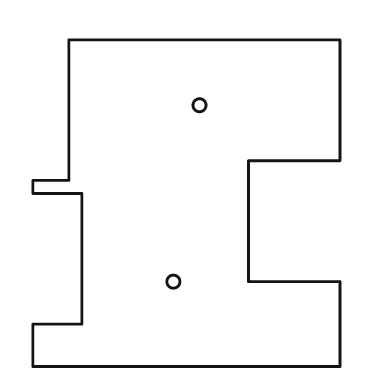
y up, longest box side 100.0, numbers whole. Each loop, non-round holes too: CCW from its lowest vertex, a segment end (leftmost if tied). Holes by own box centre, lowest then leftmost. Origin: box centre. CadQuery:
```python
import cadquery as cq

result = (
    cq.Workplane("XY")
    .moveTo(-47.0, -50.0)
    .lineTo(47.0, -50.0)
    .lineTo(47.0, -24.0)
    .lineTo(19.0, -24.0)
    .lineTo(19.0, 13.0)
    .lineTo(47.0, 13.0)
    .lineTo(47.0, 50.0)
    .lineTo(-36.0, 50.0)
    .lineTo(-36.0, 7.0)
    .lineTo(-47.0, 7.0)
    .lineTo(-47.0, 3.0)
    .lineTo(-32.0, 3.0)
    .lineTo(-32.0, -37.0)
    .lineTo(-47.0, -37.0)
    .close()
    .moveTo(-4.0, -24.0)
    .circle(2.0)
    .moveTo(4.0, 30.0)
    .circle(2.0)
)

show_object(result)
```